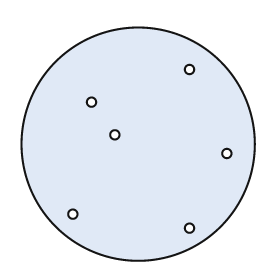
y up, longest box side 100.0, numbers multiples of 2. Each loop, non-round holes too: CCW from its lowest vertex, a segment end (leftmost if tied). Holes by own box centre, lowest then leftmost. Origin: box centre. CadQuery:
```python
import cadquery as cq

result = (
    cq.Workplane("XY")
    .moveTo(0.0, 0.0)
    .circle(50.0)
    .moveTo(22.0, -36.0)
    .circle(2.0)
    .moveTo(-28.0, -30.0)
    .circle(2.0)
    .moveTo(38.0, -4.0)
    .circle(2.0)
    .moveTo(-10.0, 4.0)
    .circle(2.0)
    .moveTo(-20.0, 18.0)
    .circle(2.0)
    .moveTo(22.0, 32.0)
    .circle(2.0)
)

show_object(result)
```